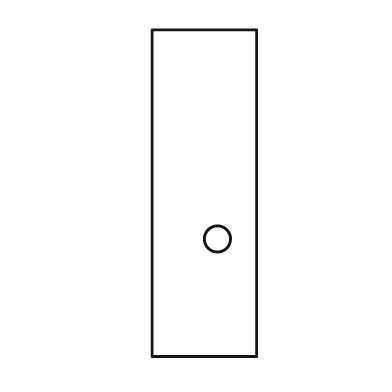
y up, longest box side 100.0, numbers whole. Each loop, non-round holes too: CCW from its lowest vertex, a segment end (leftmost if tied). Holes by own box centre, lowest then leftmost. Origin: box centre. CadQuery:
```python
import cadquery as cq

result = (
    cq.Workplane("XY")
    .moveTo(-16.0, -50.0)
    .lineTo(16.0, -50.0)
    .lineTo(16.0, 50.0)
    .lineTo(-16.0, 50.0)
    .close()
    .moveTo(4.0, -14.0)
    .circle(4.0)
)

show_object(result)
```